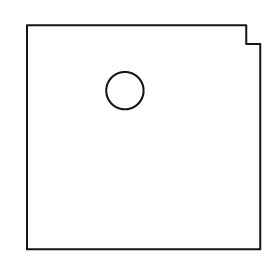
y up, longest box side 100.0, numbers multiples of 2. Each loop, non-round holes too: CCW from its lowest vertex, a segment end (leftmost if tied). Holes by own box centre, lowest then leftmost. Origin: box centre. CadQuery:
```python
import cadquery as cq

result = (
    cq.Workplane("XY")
    .moveTo(-50.0, -48.0)
    .lineTo(50.0, -48.0)
    .lineTo(50.0, 40.0)
    .lineTo(44.0, 40.0)
    .lineTo(44.0, 48.0)
    .lineTo(-50.0, 48.0)
    .close()
    .moveTo(-8.0, 20.0)
    .circle(8.0)
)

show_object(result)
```